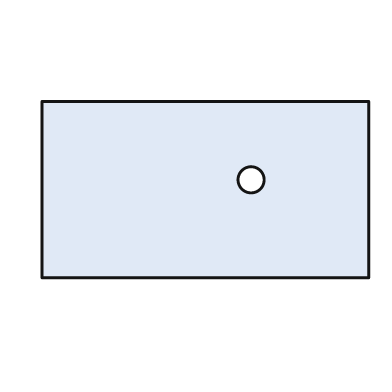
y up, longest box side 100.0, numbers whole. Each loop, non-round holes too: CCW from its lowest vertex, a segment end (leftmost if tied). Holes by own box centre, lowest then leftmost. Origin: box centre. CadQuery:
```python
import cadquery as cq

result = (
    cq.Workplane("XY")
    .moveTo(-50.0, -27.0)
    .lineTo(50.0, -27.0)
    .lineTo(50.0, 27.0)
    .lineTo(-50.0, 27.0)
    .close()
    .moveTo(14.0, 3.0)
    .circle(4.0)
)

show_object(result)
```